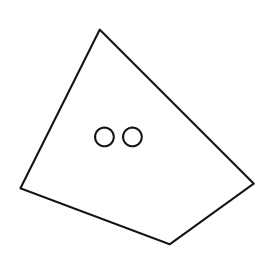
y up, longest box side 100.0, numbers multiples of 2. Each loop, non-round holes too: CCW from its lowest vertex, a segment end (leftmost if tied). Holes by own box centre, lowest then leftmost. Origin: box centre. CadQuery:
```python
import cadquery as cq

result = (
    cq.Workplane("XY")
    .moveTo(14.0, -46.0)
    .lineTo(50.0, -20.0)
    .lineTo(-16.0, 46.0)
    .lineTo(-50.0, -22.0)
    .close()
    .moveTo(-14.0, 0.0)
    .circle(4.0)
    .moveTo(-2.0, 0.0)
    .circle(4.0)
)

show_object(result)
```